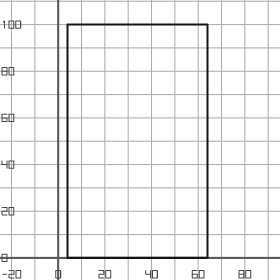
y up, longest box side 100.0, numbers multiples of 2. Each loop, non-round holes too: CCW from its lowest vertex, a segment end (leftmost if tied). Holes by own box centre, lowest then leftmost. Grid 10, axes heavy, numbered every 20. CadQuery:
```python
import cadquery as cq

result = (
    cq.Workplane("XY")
    .moveTo(4.0, 0.0)
    .lineTo(64.0, 0.0)
    .lineTo(64.0, 100.0)
    .lineTo(4.0, 100.0)
    .close()
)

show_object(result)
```